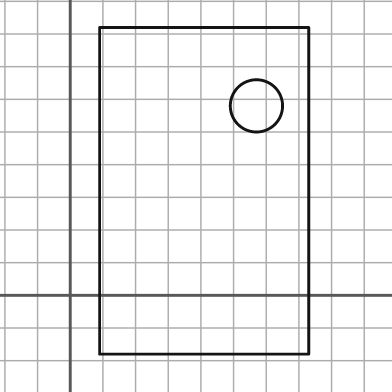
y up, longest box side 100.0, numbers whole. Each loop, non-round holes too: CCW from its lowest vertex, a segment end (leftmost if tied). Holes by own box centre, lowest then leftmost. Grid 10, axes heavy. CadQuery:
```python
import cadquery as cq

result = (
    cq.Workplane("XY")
    .moveTo(9.0, -18.0)
    .lineTo(73.0, -18.0)
    .lineTo(73.0, 82.0)
    .lineTo(9.0, 82.0)
    .close()
    .moveTo(57.0, 58.0)
    .circle(8.0)
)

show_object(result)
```